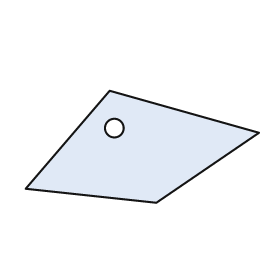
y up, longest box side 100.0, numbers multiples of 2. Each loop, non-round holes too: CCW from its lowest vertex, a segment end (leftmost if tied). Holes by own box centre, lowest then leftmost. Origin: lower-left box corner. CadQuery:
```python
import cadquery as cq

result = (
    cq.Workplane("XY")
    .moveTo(56.0, 0.0)
    .lineTo(100.0, 30.0)
    .lineTo(36.0, 48.0)
    .lineTo(0.0, 6.0)
    .close()
    .moveTo(38.0, 32.0)
    .circle(4.0)
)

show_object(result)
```